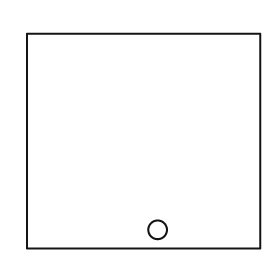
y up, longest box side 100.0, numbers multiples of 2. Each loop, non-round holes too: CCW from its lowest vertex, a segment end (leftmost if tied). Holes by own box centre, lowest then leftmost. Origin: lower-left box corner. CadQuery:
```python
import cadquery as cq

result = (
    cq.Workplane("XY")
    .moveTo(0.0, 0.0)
    .lineTo(100.0, 0.0)
    .lineTo(100.0, 92.0)
    .lineTo(0.0, 92.0)
    .close()
    .moveTo(56.0, 8.0)
    .circle(4.0)
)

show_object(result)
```